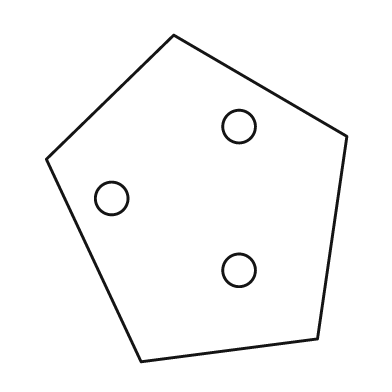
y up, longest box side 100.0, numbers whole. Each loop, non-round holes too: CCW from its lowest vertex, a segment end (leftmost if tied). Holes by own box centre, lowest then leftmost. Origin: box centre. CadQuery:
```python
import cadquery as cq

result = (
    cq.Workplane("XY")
    .moveTo(-17.0, -50.0)
    .lineTo(37.0, -43.0)
    .lineTo(46.0, 19.0)
    .lineTo(-7.0, 50.0)
    .lineTo(-46.0, 12.0)
    .close()
    .moveTo(13.0, -22.0)
    .circle(5.0)
    .moveTo(-26.0, 0.0)
    .circle(5.0)
    .moveTo(13.0, 22.0)
    .circle(5.0)
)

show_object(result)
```